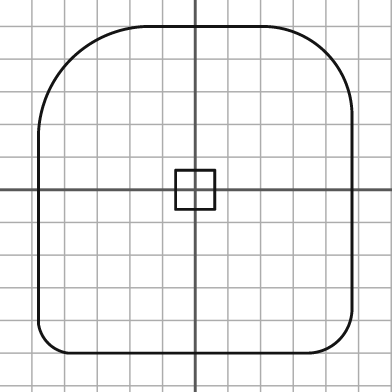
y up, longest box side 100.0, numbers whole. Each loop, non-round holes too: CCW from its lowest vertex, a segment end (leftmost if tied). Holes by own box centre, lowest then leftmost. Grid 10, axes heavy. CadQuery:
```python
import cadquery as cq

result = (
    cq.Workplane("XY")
    .moveTo(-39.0, -50.0)
    .lineTo(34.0, -50.0)
    .threePointArc((44.0, -46.0), (48.0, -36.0))
    .lineTo(48.0, 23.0)
    .threePointArc((40.0, 42.0), (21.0, 50.0))
    .lineTo(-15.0, 50.0)
    .threePointArc((-38.0, 40.0), (-48.0, 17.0))
    .lineTo(-48.0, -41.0)
    .threePointArc((-45.0, -47.0), (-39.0, -50.0))
    .close()
    .moveTo(-6.0, -6.0)
    .lineTo(6.0, -6.0)
    .lineTo(6.0, 6.0)
    .lineTo(-6.0, 6.0)
    .close()
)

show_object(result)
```